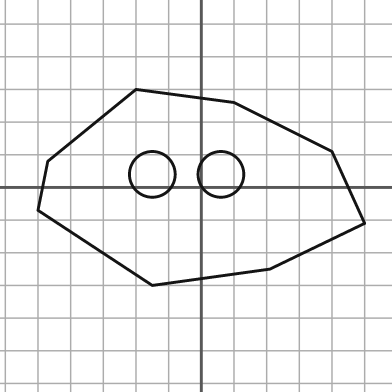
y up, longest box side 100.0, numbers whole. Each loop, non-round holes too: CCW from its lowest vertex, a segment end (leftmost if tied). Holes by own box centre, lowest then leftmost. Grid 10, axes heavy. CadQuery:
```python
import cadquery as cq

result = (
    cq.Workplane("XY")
    .moveTo(-15.0, -30.0)
    .lineTo(21.0, -25.0)
    .lineTo(50.0, -11.0)
    .lineTo(40.0, 11.0)
    .lineTo(10.0, 26.0)
    .lineTo(-20.0, 30.0)
    .lineTo(-47.0, 8.0)
    .lineTo(-50.0, -7.0)
    .close()
    .moveTo(-15.0, 4.0)
    .circle(7.0)
    .moveTo(6.0, 4.0)
    .circle(7.0)
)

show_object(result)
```